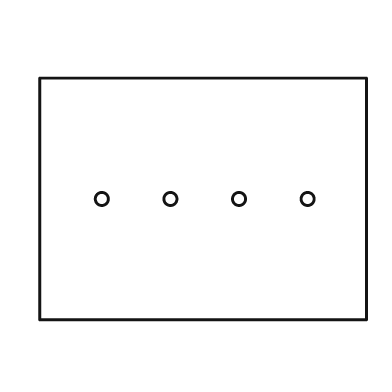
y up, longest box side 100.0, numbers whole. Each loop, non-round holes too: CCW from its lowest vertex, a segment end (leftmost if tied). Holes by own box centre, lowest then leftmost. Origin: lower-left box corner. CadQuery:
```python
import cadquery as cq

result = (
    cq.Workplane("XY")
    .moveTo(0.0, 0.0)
    .lineTo(100.0, 0.0)
    .lineTo(100.0, 74.0)
    .lineTo(0.0, 74.0)
    .close()
    .moveTo(19.0, 37.0)
    .circle(2.0)
    .moveTo(40.0, 37.0)
    .circle(2.0)
    .moveTo(61.0, 37.0)
    .circle(2.0)
    .moveTo(82.0, 37.0)
    .circle(2.0)
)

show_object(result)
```